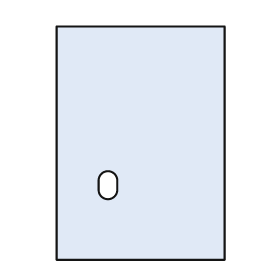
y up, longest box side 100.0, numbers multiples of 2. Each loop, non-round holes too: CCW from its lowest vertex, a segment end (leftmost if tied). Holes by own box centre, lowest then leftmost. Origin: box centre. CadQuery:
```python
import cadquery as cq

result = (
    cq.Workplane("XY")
    .moveTo(-36.0, -50.0)
    .lineTo(36.0, -50.0)
    .lineTo(36.0, 50.0)
    .lineTo(-36.0, 50.0)
    .close()
    .moveTo(-18.0, -20.0)
    .threePointArc((-14.0, -24.0), (-10.0, -20.0))
    .lineTo(-10.0, -16.0)
    .threePointArc((-14.0, -12.0), (-18.0, -16.0))
    .close()
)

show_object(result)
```